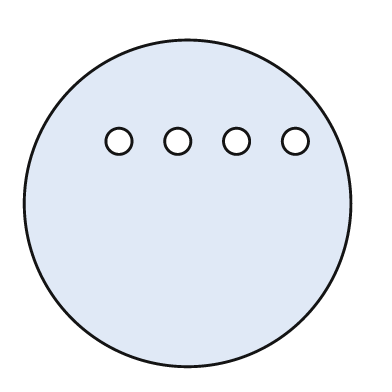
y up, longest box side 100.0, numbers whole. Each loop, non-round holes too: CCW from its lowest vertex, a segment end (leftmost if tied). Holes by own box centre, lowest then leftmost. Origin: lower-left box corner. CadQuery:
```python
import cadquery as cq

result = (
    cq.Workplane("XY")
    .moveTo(50.0, 50.0)
    .circle(50.0)
    .moveTo(29.0, 69.0)
    .circle(4.0)
    .moveTo(47.0, 69.0)
    .circle(4.0)
    .moveTo(65.0, 69.0)
    .circle(4.0)
    .moveTo(83.0, 69.0)
    .circle(4.0)
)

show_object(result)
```